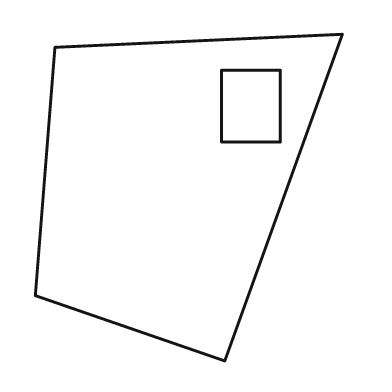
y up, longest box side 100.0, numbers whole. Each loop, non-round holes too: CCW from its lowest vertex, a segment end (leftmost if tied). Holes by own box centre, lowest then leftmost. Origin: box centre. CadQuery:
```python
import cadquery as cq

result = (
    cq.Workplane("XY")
    .moveTo(11.0, -50.0)
    .lineTo(47.0, 50.0)
    .lineTo(-41.0, 46.0)
    .lineTo(-47.0, -30.0)
    .close()
    .moveTo(10.0, 17.0)
    .lineTo(28.0, 17.0)
    .lineTo(28.0, 39.0)
    .lineTo(10.0, 39.0)
    .close()
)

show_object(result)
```